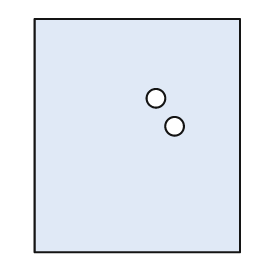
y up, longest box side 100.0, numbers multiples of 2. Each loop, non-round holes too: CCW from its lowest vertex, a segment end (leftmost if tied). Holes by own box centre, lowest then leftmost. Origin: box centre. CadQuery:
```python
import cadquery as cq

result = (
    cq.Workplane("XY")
    .moveTo(-44.0, -50.0)
    .lineTo(44.0, -50.0)
    .lineTo(44.0, 50.0)
    .lineTo(-44.0, 50.0)
    .close()
    .moveTo(16.0, 4.0)
    .circle(4.0)
    .moveTo(8.0, 16.0)
    .circle(4.0)
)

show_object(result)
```